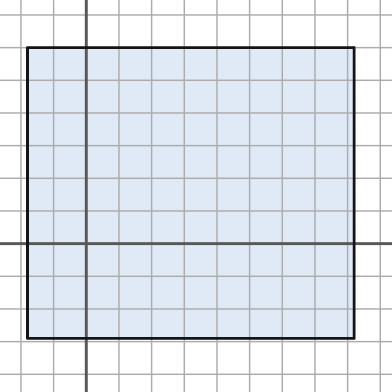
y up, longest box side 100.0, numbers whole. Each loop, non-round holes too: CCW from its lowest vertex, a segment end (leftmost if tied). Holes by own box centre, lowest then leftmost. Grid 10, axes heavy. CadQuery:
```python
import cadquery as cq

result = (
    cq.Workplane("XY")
    .moveTo(-18.0, -29.0)
    .lineTo(82.0, -29.0)
    .lineTo(82.0, 60.0)
    .lineTo(-18.0, 60.0)
    .close()
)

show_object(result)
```